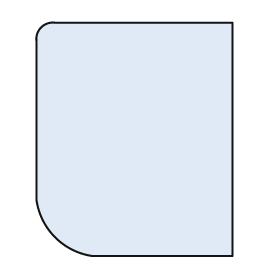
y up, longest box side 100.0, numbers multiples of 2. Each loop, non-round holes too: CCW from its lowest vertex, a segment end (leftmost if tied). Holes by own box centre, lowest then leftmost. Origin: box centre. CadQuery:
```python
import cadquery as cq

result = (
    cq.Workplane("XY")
    .moveTo(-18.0, -50.0)
    .lineTo(42.0, -50.0)
    .lineTo(42.0, 50.0)
    .lineTo(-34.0, 50.0)
    .threePointArc((-40.0, 48.0), (-42.0, 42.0))
    .lineTo(-42.0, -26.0)
    .threePointArc((-34.0, -42.0), (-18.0, -50.0))
    .close()
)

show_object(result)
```